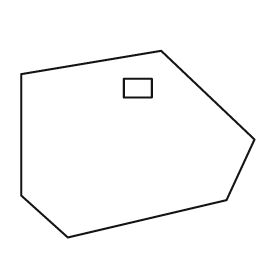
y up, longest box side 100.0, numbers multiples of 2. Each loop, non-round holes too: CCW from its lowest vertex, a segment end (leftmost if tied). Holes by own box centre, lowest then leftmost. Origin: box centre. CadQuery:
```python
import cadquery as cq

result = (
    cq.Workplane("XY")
    .moveTo(-30.0, -40.0)
    .lineTo(38.0, -24.0)
    .lineTo(50.0, 2.0)
    .lineTo(10.0, 40.0)
    .lineTo(-50.0, 30.0)
    .lineTo(-50.0, -22.0)
    .close()
    .moveTo(-6.0, 20.0)
    .lineTo(6.0, 20.0)
    .lineTo(6.0, 28.0)
    .lineTo(-6.0, 28.0)
    .close()
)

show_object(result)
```